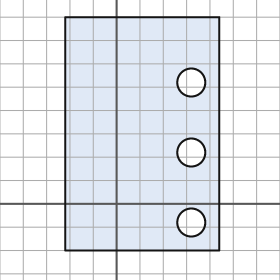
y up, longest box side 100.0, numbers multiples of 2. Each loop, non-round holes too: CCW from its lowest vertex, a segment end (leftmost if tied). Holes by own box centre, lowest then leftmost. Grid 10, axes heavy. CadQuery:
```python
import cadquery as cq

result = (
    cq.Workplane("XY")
    .moveTo(-22.0, -20.0)
    .lineTo(44.0, -20.0)
    .lineTo(44.0, 80.0)
    .lineTo(-22.0, 80.0)
    .close()
    .moveTo(32.0, -8.0)
    .circle(6.0)
    .moveTo(32.0, 22.0)
    .circle(6.0)
    .moveTo(32.0, 52.0)
    .circle(6.0)
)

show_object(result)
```